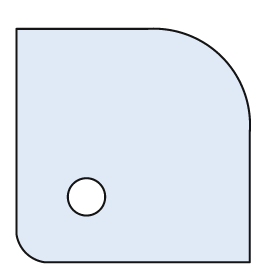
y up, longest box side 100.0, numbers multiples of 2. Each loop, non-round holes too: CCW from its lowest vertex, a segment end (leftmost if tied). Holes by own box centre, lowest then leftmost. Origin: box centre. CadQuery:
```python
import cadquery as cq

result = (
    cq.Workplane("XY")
    .moveTo(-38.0, -50.0)
    .lineTo(50.0, -50.0)
    .lineTo(50.0, 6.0)
    .threePointArc((38.0, 38.0), (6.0, 50.0))
    .lineTo(-50.0, 50.0)
    .lineTo(-50.0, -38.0)
    .threePointArc((-46.0, -46.0), (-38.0, -50.0))
    .close()
    .moveTo(-20.0, -22.0)
    .circle(8.0)
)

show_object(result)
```